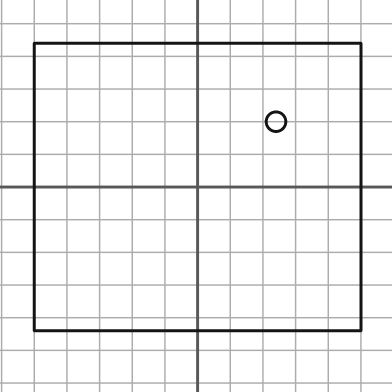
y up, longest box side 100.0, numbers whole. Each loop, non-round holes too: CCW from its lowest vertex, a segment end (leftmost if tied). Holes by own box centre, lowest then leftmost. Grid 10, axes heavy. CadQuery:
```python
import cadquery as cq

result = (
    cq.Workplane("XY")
    .moveTo(-50.0, -44.0)
    .lineTo(50.0, -44.0)
    .lineTo(50.0, 44.0)
    .lineTo(-50.0, 44.0)
    .close()
    .moveTo(24.0, 20.0)
    .circle(3.0)
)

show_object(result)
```